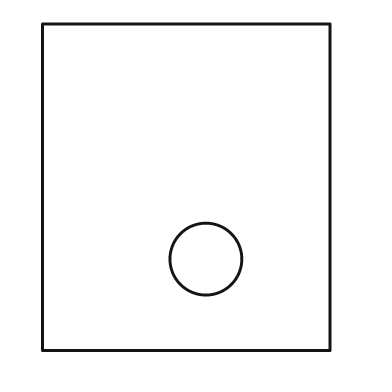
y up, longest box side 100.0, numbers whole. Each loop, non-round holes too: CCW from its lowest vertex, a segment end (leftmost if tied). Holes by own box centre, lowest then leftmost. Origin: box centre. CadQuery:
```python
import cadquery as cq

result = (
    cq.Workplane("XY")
    .moveTo(-44.0, -50.0)
    .lineTo(44.0, -50.0)
    .lineTo(44.0, 50.0)
    .lineTo(-44.0, 50.0)
    .close()
    .moveTo(6.0, -22.0)
    .circle(11.0)
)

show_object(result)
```